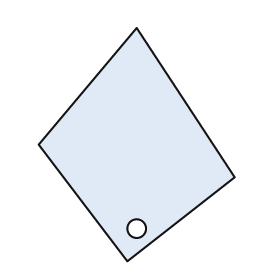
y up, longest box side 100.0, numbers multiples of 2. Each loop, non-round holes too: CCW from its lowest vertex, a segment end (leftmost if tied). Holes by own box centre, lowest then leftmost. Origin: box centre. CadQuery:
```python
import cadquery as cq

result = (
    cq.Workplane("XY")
    .moveTo(-4.0, -50.0)
    .lineTo(42.0, -14.0)
    .lineTo(0.0, 50.0)
    .lineTo(-42.0, 0.0)
    .close()
    .moveTo(0.0, -36.0)
    .circle(4.0)
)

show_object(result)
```